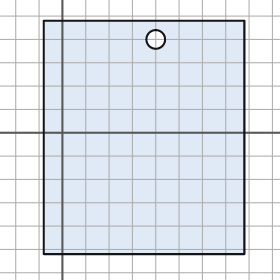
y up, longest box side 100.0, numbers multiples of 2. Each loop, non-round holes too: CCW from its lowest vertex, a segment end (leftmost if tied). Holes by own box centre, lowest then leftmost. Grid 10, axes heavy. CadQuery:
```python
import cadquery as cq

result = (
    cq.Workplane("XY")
    .moveTo(-8.0, -52.0)
    .lineTo(78.0, -52.0)
    .lineTo(78.0, 48.0)
    .lineTo(-8.0, 48.0)
    .close()
    .moveTo(40.0, 40.0)
    .circle(4.0)
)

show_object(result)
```